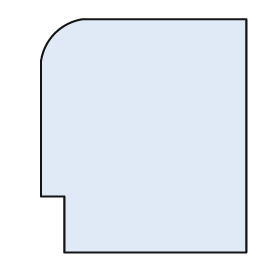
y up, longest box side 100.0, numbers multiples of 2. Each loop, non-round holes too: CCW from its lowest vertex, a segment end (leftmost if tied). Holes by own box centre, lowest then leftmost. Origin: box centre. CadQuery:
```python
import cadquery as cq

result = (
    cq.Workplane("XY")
    .moveTo(-34.0, -50.0)
    .lineTo(44.0, -50.0)
    .lineTo(44.0, 50.0)
    .lineTo(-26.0, 50.0)
    .threePointArc((-38.0, 44.0), (-44.0, 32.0))
    .lineTo(-44.0, -26.0)
    .lineTo(-34.0, -26.0)
    .close()
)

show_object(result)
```